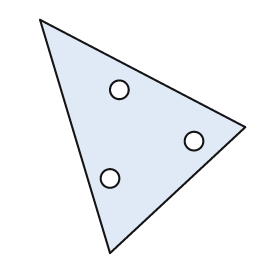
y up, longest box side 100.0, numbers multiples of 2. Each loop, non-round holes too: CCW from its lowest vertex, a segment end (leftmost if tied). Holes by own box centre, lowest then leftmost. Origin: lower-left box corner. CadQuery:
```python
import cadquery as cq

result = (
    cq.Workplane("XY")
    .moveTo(30.0, 0.0)
    .lineTo(88.0, 54.0)
    .lineTo(0.0, 100.0)
    .close()
    .moveTo(30.0, 32.0)
    .circle(4.0)
    .moveTo(66.0, 48.0)
    .circle(4.0)
    .moveTo(34.0, 70.0)
    .circle(4.0)
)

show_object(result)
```